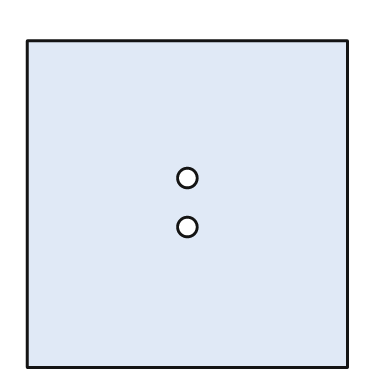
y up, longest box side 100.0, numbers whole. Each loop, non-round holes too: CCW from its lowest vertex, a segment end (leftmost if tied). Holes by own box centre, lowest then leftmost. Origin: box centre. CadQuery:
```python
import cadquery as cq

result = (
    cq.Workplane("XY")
    .moveTo(-49.0, -50.0)
    .lineTo(49.0, -50.0)
    .lineTo(49.0, 50.0)
    .lineTo(-49.0, 50.0)
    .close()
    .moveTo(0.0, -7.0)
    .circle(3.0)
    .moveTo(0.0, 8.0)
    .circle(3.0)
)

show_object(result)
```